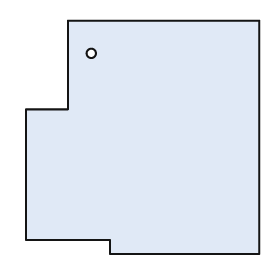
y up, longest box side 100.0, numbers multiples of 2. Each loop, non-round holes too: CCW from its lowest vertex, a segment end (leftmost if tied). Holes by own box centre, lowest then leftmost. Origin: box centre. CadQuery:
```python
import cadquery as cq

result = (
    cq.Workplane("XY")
    .moveTo(-14.0, -50.0)
    .lineTo(50.0, -50.0)
    .lineTo(50.0, 50.0)
    .lineTo(-32.0, 50.0)
    .lineTo(-32.0, 12.0)
    .lineTo(-50.0, 12.0)
    .lineTo(-50.0, -44.0)
    .lineTo(-14.0, -44.0)
    .close()
    .moveTo(-22.0, 36.0)
    .circle(2.0)
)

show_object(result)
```